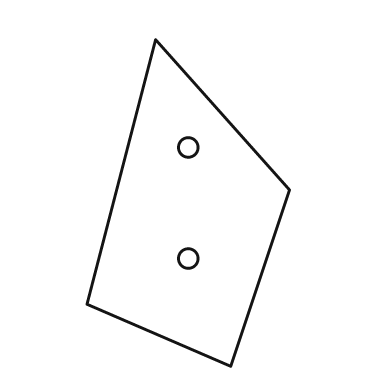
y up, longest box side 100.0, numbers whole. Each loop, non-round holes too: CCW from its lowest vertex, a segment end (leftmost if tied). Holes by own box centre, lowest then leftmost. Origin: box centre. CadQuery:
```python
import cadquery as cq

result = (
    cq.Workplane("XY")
    .moveTo(13.0, -50.0)
    .lineTo(31.0, 4.0)
    .lineTo(-10.0, 50.0)
    .lineTo(-31.0, -31.0)
    .close()
    .moveTo(0.0, -17.0)
    .circle(3.0)
    .moveTo(0.0, 17.0)
    .circle(3.0)
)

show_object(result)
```